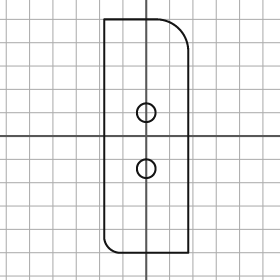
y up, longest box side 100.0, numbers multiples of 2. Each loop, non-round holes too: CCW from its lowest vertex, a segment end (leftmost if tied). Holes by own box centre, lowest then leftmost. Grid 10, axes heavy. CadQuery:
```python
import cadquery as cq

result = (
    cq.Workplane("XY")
    .moveTo(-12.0, -50.0)
    .lineTo(18.0, -50.0)
    .lineTo(18.0, 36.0)
    .threePointArc((14.0, 46.0), (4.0, 50.0))
    .lineTo(-18.0, 50.0)
    .lineTo(-18.0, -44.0)
    .threePointArc((-16.0, -48.0), (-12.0, -50.0))
    .close()
    .moveTo(0.0, -14.0)
    .circle(4.0)
    .moveTo(0.0, 10.0)
    .circle(4.0)
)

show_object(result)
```